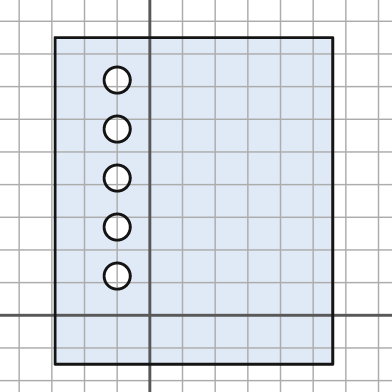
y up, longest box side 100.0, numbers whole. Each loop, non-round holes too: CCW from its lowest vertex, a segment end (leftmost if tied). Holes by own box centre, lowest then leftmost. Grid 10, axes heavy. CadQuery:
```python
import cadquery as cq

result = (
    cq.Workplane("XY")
    .moveTo(-29.0, -15.0)
    .lineTo(56.0, -15.0)
    .lineTo(56.0, 85.0)
    .lineTo(-29.0, 85.0)
    .close()
    .moveTo(-10.0, 12.0)
    .circle(4.0)
    .moveTo(-10.0, 27.0)
    .circle(4.0)
    .moveTo(-10.0, 42.0)
    .circle(4.0)
    .moveTo(-10.0, 57.0)
    .circle(4.0)
    .moveTo(-10.0, 72.0)
    .circle(4.0)
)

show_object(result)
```